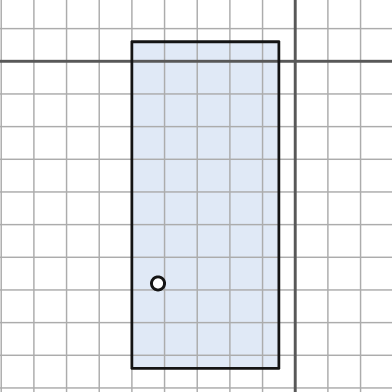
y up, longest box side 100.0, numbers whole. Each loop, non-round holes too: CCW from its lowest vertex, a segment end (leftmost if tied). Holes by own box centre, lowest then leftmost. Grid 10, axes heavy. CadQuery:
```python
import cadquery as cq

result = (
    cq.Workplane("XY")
    .moveTo(-50.0, -94.0)
    .lineTo(-5.0, -94.0)
    .lineTo(-5.0, 6.0)
    .lineTo(-50.0, 6.0)
    .close()
    .moveTo(-42.0, -68.0)
    .circle(2.0)
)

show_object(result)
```